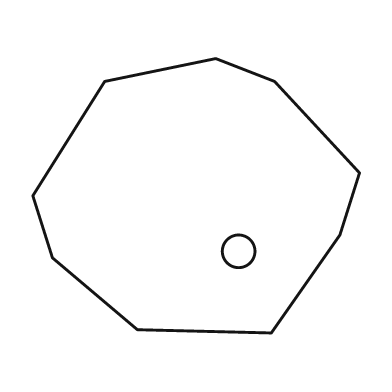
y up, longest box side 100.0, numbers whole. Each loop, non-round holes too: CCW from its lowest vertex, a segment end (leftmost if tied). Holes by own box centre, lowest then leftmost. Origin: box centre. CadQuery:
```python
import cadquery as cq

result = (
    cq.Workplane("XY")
    .moveTo(23.0, -42.0)
    .lineTo(44.0, -12.0)
    .lineTo(50.0, 7.0)
    .lineTo(24.0, 35.0)
    .lineTo(6.0, 42.0)
    .lineTo(-28.0, 35.0)
    .lineTo(-50.0, 0.0)
    .lineTo(-44.0, -19.0)
    .lineTo(-18.0, -41.0)
    .close()
    .moveTo(13.0, -17.0)
    .circle(5.0)
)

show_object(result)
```